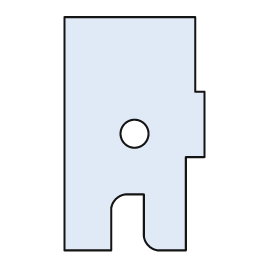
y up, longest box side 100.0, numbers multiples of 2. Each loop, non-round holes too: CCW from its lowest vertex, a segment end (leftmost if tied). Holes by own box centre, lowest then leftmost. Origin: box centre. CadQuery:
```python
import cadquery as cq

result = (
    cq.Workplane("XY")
    .moveTo(-30.0, -50.0)
    .lineTo(-10.0, -50.0)
    .lineTo(-10.0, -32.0)
    .threePointArc((-8.0, -28.0), (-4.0, -26.0))
    .lineTo(4.0, -26.0)
    .lineTo(4.0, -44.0)
    .threePointArc((6.0, -48.0), (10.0, -50.0))
    .lineTo(22.0, -50.0)
    .lineTo(22.0, -10.0)
    .lineTo(30.0, -10.0)
    .lineTo(30.0, 18.0)
    .lineTo(26.0, 18.0)
    .lineTo(26.0, 50.0)
    .lineTo(-30.0, 50.0)
    .close()
    .moveTo(0.0, 0.0)
    .circle(6.0)
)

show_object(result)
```